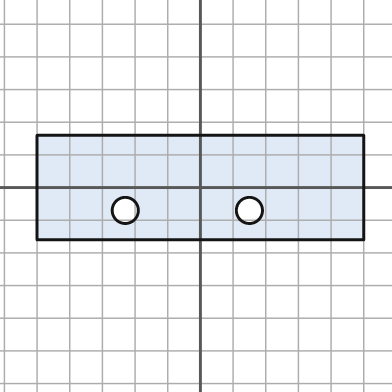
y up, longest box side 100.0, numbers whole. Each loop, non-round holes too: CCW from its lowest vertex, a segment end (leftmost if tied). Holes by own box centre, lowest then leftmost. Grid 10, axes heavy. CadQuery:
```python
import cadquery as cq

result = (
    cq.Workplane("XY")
    .moveTo(-50.0, -16.0)
    .lineTo(50.0, -16.0)
    .lineTo(50.0, 16.0)
    .lineTo(-50.0, 16.0)
    .close()
    .moveTo(-23.0, -7.0)
    .circle(4.0)
    .moveTo(15.0, -7.0)
    .circle(4.0)
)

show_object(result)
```